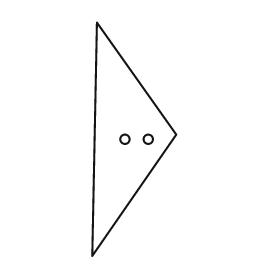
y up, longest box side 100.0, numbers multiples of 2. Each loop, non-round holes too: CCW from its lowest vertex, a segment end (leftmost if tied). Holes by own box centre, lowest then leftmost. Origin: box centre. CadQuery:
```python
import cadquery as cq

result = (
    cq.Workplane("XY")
    .moveTo(-18.0, -50.0)
    .lineTo(18.0, 2.0)
    .lineTo(-16.0, 50.0)
    .close()
    .moveTo(-4.0, 0.0)
    .circle(2.0)
    .moveTo(6.0, 0.0)
    .circle(2.0)
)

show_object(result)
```